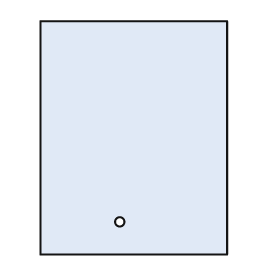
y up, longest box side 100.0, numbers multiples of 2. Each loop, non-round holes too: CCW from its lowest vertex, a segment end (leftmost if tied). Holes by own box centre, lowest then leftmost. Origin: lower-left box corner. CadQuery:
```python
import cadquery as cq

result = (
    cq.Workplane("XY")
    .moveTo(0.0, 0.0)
    .lineTo(80.0, 0.0)
    .lineTo(80.0, 100.0)
    .lineTo(0.0, 100.0)
    .close()
    .moveTo(34.0, 14.0)
    .circle(2.0)
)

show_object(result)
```